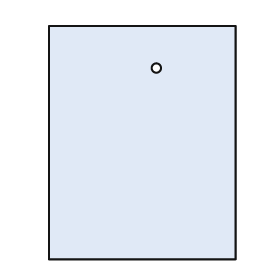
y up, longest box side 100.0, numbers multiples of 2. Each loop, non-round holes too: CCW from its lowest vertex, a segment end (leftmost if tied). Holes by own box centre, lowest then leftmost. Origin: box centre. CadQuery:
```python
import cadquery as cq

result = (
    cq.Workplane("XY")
    .moveTo(-40.0, -50.0)
    .lineTo(40.0, -50.0)
    .lineTo(40.0, 50.0)
    .lineTo(-40.0, 50.0)
    .close()
    .moveTo(6.0, 32.0)
    .circle(2.0)
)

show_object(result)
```